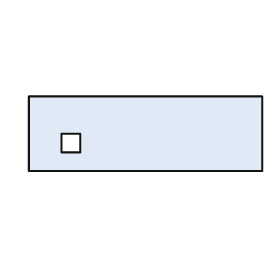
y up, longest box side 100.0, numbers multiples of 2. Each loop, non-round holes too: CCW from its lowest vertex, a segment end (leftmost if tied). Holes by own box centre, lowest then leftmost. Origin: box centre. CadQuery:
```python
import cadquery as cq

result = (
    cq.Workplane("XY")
    .moveTo(-50.0, -16.0)
    .lineTo(50.0, -16.0)
    .lineTo(50.0, 16.0)
    .lineTo(-50.0, 16.0)
    .close()
    .moveTo(-36.0, -8.0)
    .lineTo(-28.0, -8.0)
    .lineTo(-28.0, 0.0)
    .lineTo(-36.0, 0.0)
    .close()
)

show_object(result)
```